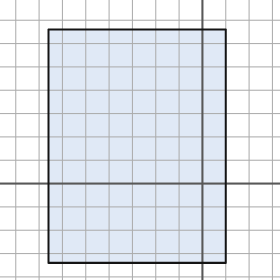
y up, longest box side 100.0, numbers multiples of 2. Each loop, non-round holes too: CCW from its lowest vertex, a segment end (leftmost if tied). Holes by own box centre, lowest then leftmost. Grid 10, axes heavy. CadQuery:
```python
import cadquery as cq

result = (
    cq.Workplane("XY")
    .moveTo(-66.0, -34.0)
    .lineTo(10.0, -34.0)
    .lineTo(10.0, 66.0)
    .lineTo(-66.0, 66.0)
    .close()
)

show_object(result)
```